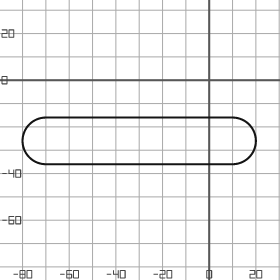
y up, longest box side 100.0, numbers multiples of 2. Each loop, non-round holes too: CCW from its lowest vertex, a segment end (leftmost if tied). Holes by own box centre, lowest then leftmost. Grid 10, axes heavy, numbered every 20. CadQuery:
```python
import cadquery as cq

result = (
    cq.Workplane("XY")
    .moveTo(-70.0, -36.0)
    .lineTo(10.0, -36.0)
    .threePointArc((20.0, -26.0), (10.0, -16.0))
    .lineTo(-70.0, -16.0)
    .threePointArc((-80.0, -26.0), (-70.0, -36.0))
    .close()
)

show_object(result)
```